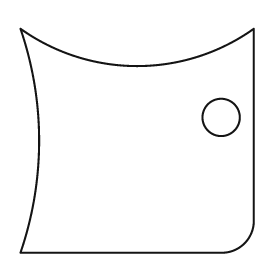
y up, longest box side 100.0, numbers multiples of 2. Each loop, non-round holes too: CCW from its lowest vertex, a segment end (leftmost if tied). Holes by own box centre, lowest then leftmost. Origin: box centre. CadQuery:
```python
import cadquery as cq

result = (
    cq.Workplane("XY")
    .moveTo(-50.0, -48.0)
    .lineTo(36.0, -48.0)
    .threePointArc((46.0, -44.0), (50.0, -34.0))
    .lineTo(50.0, 48.0)
    .threePointArc((0.0, 32.0), (-50.0, 48.0))
    .threePointArc((-42.0, 0.0), (-50.0, -48.0))
    .close()
    .moveTo(36.0, 10.0)
    .circle(8.0)
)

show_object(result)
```